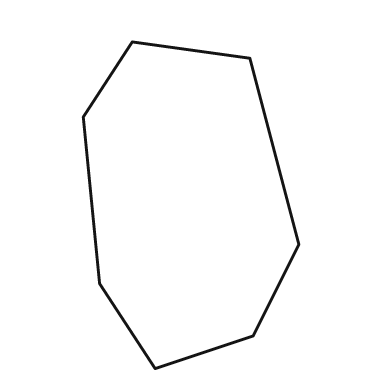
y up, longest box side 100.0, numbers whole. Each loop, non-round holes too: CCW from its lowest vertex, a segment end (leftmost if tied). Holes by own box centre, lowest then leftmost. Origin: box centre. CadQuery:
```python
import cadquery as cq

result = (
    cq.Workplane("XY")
    .moveTo(-11.0, -50.0)
    .lineTo(19.0, -40.0)
    .lineTo(33.0, -12.0)
    .lineTo(18.0, 45.0)
    .lineTo(-18.0, 50.0)
    .lineTo(-33.0, 27.0)
    .lineTo(-28.0, -24.0)
    .close()
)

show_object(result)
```